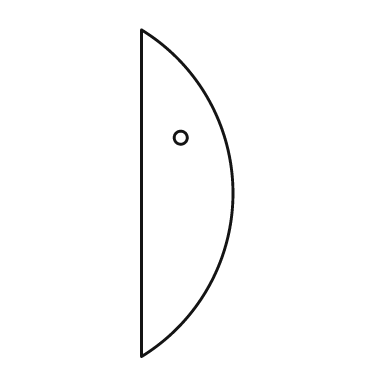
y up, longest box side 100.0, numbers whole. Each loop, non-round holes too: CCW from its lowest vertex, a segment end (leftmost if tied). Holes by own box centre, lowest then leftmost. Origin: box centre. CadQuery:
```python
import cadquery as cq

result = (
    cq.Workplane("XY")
    .moveTo(-14.0, -50.0)
    .threePointArc((14.0, 0.0), (-14.0, 50.0))
    .close()
    .moveTo(-2.0, 17.0)
    .circle(2.0)
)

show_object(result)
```